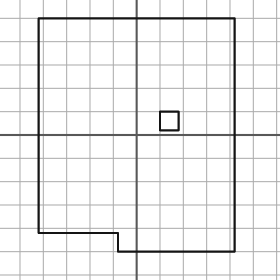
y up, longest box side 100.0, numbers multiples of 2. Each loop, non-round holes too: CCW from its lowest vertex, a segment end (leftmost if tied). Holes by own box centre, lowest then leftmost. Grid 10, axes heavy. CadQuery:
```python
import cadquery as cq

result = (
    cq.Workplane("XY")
    .moveTo(-8.0, -50.0)
    .lineTo(42.0, -50.0)
    .lineTo(42.0, 50.0)
    .lineTo(-42.0, 50.0)
    .lineTo(-42.0, -42.0)
    .lineTo(-8.0, -42.0)
    .close()
    .moveTo(10.0, 2.0)
    .lineTo(18.0, 2.0)
    .lineTo(18.0, 10.0)
    .lineTo(10.0, 10.0)
    .close()
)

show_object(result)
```